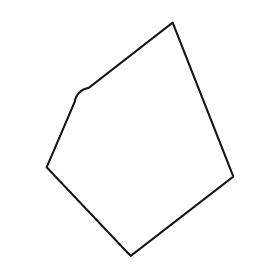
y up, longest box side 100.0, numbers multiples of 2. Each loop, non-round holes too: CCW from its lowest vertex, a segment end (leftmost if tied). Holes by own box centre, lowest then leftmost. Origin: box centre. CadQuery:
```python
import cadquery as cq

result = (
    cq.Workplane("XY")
    .moveTo(-4.0, -50.0)
    .lineTo(40.0, -16.0)
    .lineTo(14.0, 50.0)
    .lineTo(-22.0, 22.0)
    .threePointArc((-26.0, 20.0), (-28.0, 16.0))
    .lineTo(-40.0, -12.0)
    .close()
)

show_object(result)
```